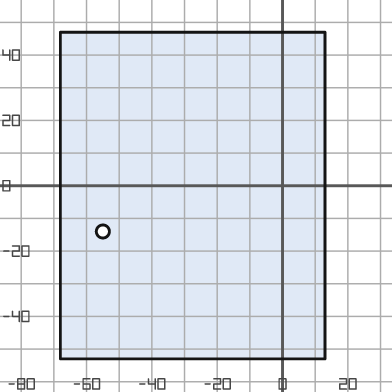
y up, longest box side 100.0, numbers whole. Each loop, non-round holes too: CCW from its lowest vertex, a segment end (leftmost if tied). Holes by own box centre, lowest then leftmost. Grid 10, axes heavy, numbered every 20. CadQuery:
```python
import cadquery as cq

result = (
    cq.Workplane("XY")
    .moveTo(-68.0, -53.0)
    .lineTo(13.0, -53.0)
    .lineTo(13.0, 47.0)
    .lineTo(-68.0, 47.0)
    .close()
    .moveTo(-55.0, -14.0)
    .circle(2.0)
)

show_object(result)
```